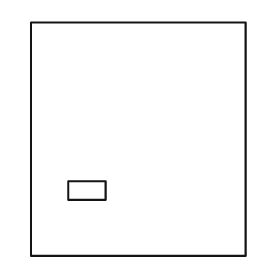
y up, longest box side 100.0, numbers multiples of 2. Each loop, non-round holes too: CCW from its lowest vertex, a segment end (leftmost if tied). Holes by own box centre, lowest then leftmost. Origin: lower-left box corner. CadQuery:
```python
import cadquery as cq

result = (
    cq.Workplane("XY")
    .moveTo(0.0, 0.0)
    .lineTo(92.0, 0.0)
    .lineTo(92.0, 100.0)
    .lineTo(0.0, 100.0)
    .close()
    .moveTo(16.0, 24.0)
    .lineTo(32.0, 24.0)
    .lineTo(32.0, 32.0)
    .lineTo(16.0, 32.0)
    .close()
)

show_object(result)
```